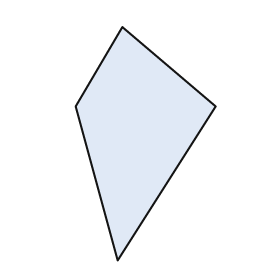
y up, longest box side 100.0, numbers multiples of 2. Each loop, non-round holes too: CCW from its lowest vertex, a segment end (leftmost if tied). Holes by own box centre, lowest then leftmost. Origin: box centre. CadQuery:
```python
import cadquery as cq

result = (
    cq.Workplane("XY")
    .moveTo(-12.0, -50.0)
    .lineTo(30.0, 16.0)
    .lineTo(-10.0, 50.0)
    .lineTo(-30.0, 16.0)
    .close()
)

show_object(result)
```